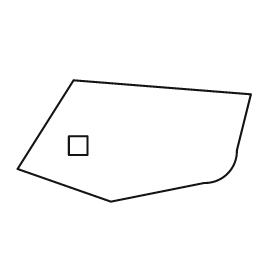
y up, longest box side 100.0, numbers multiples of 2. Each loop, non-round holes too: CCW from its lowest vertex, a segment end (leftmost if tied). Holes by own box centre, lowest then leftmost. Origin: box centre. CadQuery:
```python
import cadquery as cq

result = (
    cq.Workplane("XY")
    .moveTo(-10.0, -26.0)
    .lineTo(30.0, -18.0)
    .threePointArc((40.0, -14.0), (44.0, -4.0))
    .lineTo(50.0, 20.0)
    .lineTo(-26.0, 26.0)
    .lineTo(-50.0, -12.0)
    .close()
    .moveTo(-28.0, -6.0)
    .lineTo(-20.0, -6.0)
    .lineTo(-20.0, 2.0)
    .lineTo(-28.0, 2.0)
    .close()
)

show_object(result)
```